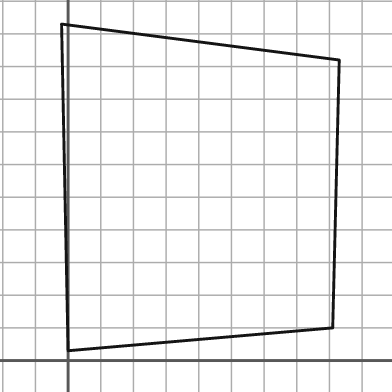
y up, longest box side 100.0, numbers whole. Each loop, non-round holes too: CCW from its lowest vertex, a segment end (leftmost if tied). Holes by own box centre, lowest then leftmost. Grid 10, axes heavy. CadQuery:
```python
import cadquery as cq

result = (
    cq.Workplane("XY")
    .moveTo(0.0, 3.0)
    .lineTo(81.0, 10.0)
    .lineTo(83.0, 92.0)
    .lineTo(-2.0, 103.0)
    .close()
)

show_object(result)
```